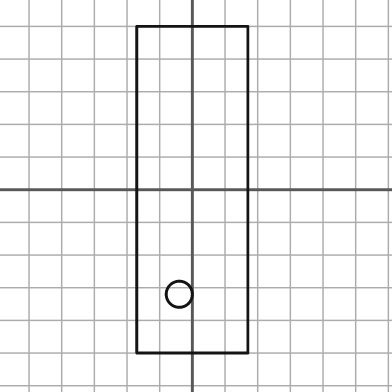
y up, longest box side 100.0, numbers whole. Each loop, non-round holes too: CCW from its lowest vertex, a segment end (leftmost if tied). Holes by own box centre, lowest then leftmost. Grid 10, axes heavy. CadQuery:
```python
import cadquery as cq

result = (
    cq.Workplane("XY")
    .moveTo(-17.0, -50.0)
    .lineTo(17.0, -50.0)
    .lineTo(17.0, 50.0)
    .lineTo(-17.0, 50.0)
    .close()
    .moveTo(-4.0, -32.0)
    .circle(4.0)
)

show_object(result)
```